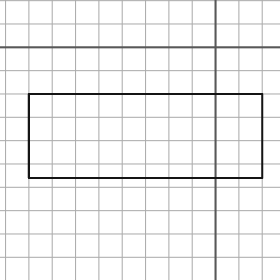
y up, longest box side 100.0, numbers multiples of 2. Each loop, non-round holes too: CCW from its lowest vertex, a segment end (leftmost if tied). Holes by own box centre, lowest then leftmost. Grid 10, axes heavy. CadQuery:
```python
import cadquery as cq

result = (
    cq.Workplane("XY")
    .moveTo(-80.0, -56.0)
    .lineTo(20.0, -56.0)
    .lineTo(20.0, -20.0)
    .lineTo(-80.0, -20.0)
    .close()
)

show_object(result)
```